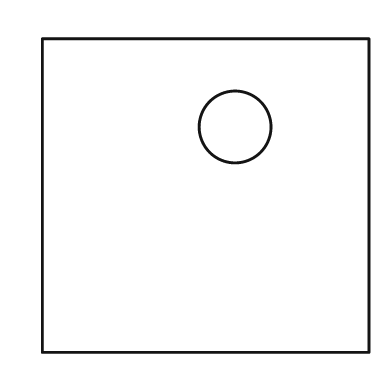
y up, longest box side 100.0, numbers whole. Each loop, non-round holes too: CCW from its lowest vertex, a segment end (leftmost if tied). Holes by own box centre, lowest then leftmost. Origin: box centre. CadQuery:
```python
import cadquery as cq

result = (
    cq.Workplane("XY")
    .moveTo(-50.0, -48.0)
    .lineTo(50.0, -48.0)
    .lineTo(50.0, 48.0)
    .lineTo(-50.0, 48.0)
    .close()
    .moveTo(9.0, 21.0)
    .circle(11.0)
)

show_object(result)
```